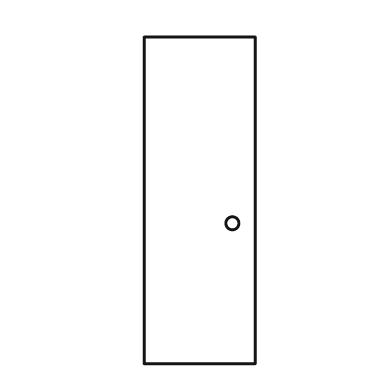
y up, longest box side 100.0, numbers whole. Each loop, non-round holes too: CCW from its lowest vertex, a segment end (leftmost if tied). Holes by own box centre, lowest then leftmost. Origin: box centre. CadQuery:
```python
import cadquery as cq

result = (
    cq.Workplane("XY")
    .moveTo(-17.0, -50.0)
    .lineTo(17.0, -50.0)
    .lineTo(17.0, 50.0)
    .lineTo(-17.0, 50.0)
    .close()
    .moveTo(10.0, -7.0)
    .circle(2.0)
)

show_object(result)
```